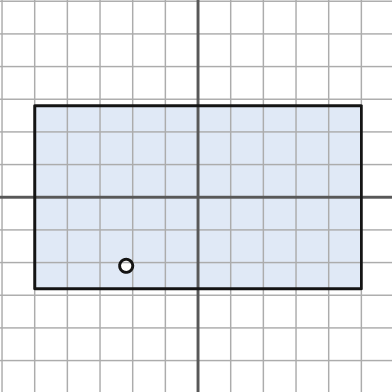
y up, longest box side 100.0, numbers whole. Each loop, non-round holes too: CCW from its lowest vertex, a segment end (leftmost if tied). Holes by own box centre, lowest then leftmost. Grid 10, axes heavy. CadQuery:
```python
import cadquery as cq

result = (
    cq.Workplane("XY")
    .moveTo(-50.0, -28.0)
    .lineTo(50.0, -28.0)
    .lineTo(50.0, 28.0)
    .lineTo(-50.0, 28.0)
    .close()
    .moveTo(-22.0, -21.0)
    .circle(2.0)
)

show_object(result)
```